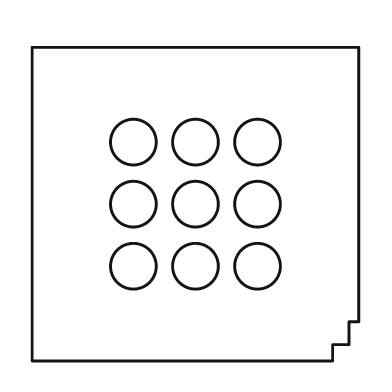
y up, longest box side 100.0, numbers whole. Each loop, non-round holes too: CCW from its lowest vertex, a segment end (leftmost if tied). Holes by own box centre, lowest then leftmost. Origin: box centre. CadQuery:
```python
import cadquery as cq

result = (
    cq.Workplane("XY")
    .moveTo(-50.0, -48.0)
    .lineTo(42.0, -48.0)
    .lineTo(42.0, -43.0)
    .lineTo(47.0, -43.0)
    .lineTo(47.0, -36.0)
    .lineTo(50.0, -36.0)
    .lineTo(50.0, 48.0)
    .lineTo(-50.0, 48.0)
    .close()
    .moveTo(-19.0, -19.0)
    .circle(7.0)
    .moveTo(0.0, -19.0)
    .circle(7.0)
    .moveTo(19.0, -19.0)
    .circle(7.0)
    .moveTo(-19.0, 0.0)
    .circle(7.0)
    .moveTo(0.0, 0.0)
    .circle(7.0)
    .moveTo(19.0, 0.0)
    .circle(7.0)
    .moveTo(-19.0, 19.0)
    .circle(7.0)
    .moveTo(0.0, 19.0)
    .circle(7.0)
    .moveTo(19.0, 19.0)
    .circle(7.0)
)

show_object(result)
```